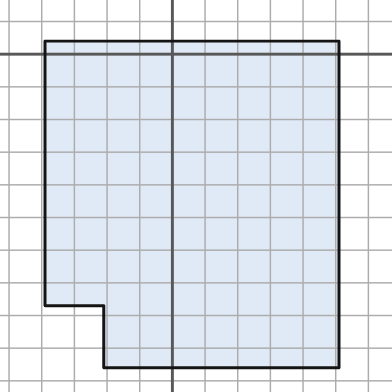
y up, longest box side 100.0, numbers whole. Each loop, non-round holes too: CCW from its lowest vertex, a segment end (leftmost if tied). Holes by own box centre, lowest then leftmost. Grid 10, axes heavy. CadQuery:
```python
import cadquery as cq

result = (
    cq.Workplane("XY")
    .moveTo(-21.0, -96.0)
    .lineTo(51.0, -96.0)
    .lineTo(51.0, 4.0)
    .lineTo(-39.0, 4.0)
    .lineTo(-39.0, -77.0)
    .lineTo(-21.0, -77.0)
    .close()
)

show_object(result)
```